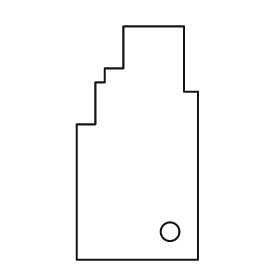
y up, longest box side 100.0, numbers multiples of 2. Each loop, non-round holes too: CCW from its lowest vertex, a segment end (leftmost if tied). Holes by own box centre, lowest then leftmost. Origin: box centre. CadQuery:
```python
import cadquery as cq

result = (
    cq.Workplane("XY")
    .moveTo(-26.0, -50.0)
    .lineTo(26.0, -50.0)
    .lineTo(26.0, 22.0)
    .lineTo(20.0, 22.0)
    .lineTo(20.0, 50.0)
    .lineTo(-6.0, 50.0)
    .lineTo(-6.0, 32.0)
    .lineTo(-14.0, 32.0)
    .lineTo(-14.0, 26.0)
    .lineTo(-18.0, 26.0)
    .lineTo(-18.0, 8.0)
    .lineTo(-26.0, 8.0)
    .close()
    .moveTo(14.0, -38.0)
    .circle(4.0)
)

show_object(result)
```